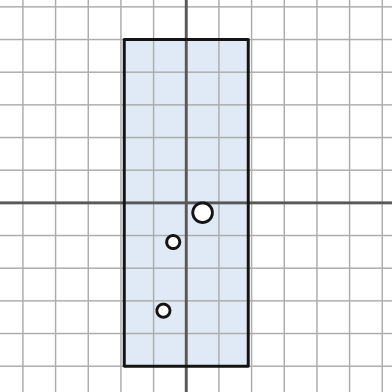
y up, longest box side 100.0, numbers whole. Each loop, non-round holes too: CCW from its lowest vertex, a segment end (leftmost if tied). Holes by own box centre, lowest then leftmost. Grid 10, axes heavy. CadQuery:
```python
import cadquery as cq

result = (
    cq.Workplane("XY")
    .moveTo(-19.0, -50.0)
    .lineTo(19.0, -50.0)
    .lineTo(19.0, 50.0)
    .lineTo(-19.0, 50.0)
    .close()
    .moveTo(-7.0, -33.0)
    .circle(2.0)
    .moveTo(-4.0, -12.0)
    .circle(2.0)
    .moveTo(5.0, -3.0)
    .circle(3.0)
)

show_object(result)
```